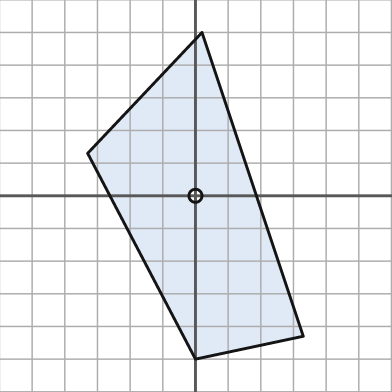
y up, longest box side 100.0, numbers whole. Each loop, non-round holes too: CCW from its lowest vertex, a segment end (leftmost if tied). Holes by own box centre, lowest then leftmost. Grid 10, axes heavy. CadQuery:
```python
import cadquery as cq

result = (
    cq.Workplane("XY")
    .moveTo(0.0, -50.0)
    .lineTo(33.0, -43.0)
    .lineTo(2.0, 50.0)
    .lineTo(-33.0, 13.0)
    .close()
    .moveTo(0.0, 0.0)
    .circle(2.0)
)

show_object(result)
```